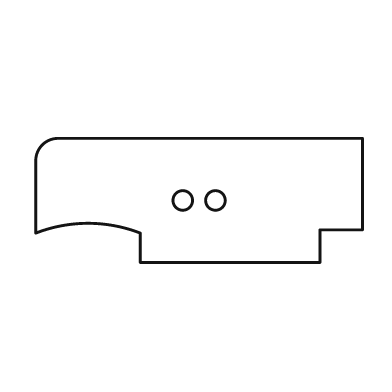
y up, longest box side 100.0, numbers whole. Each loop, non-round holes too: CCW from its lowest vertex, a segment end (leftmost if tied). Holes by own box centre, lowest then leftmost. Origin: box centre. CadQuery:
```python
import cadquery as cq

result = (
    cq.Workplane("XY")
    .moveTo(-18.0, -19.0)
    .lineTo(37.0, -19.0)
    .lineTo(37.0, -9.0)
    .lineTo(50.0, -9.0)
    .lineTo(50.0, 19.0)
    .lineTo(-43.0, 19.0)
    .threePointArc((-48.0, 17.0), (-50.0, 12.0))
    .lineTo(-50.0, -10.0)
    .threePointArc((-34.0, -7.0), (-18.0, -10.0))
    .close()
    .moveTo(-5.0, 0.0)
    .circle(3.0)
    .moveTo(5.0, 0.0)
    .circle(3.0)
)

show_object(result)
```